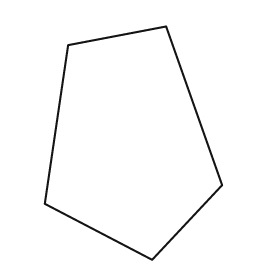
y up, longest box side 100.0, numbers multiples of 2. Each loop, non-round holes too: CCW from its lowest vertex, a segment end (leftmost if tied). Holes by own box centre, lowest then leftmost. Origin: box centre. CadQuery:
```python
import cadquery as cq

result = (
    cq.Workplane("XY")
    .moveTo(8.0, -50.0)
    .lineTo(38.0, -18.0)
    .lineTo(14.0, 50.0)
    .lineTo(-28.0, 42.0)
    .lineTo(-38.0, -26.0)
    .close()
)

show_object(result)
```